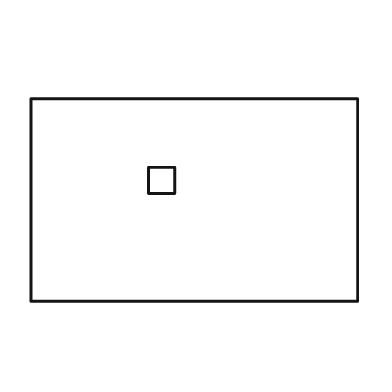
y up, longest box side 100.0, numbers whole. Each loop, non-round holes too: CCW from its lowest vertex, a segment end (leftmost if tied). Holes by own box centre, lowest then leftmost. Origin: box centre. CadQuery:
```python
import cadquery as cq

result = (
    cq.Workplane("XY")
    .moveTo(-50.0, -31.0)
    .lineTo(50.0, -31.0)
    .lineTo(50.0, 31.0)
    .lineTo(-50.0, 31.0)
    .close()
    .moveTo(-14.0, 2.0)
    .lineTo(-6.0, 2.0)
    .lineTo(-6.0, 10.0)
    .lineTo(-14.0, 10.0)
    .close()
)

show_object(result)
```